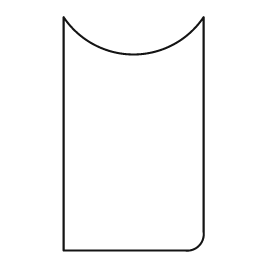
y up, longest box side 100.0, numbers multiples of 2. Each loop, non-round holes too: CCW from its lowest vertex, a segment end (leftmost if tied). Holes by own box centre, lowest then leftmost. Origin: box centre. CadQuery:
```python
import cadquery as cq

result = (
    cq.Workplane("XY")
    .moveTo(-30.0, -50.0)
    .lineTo(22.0, -50.0)
    .threePointArc((28.0, -48.0), (30.0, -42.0))
    .lineTo(30.0, 50.0)
    .threePointArc((0.0, 34.0), (-30.0, 50.0))
    .close()
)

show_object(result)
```